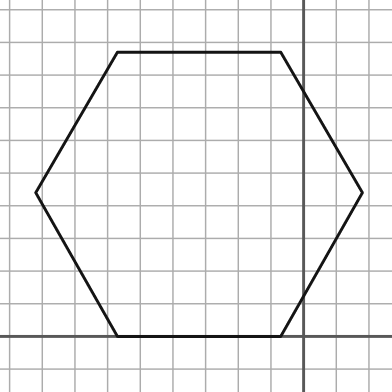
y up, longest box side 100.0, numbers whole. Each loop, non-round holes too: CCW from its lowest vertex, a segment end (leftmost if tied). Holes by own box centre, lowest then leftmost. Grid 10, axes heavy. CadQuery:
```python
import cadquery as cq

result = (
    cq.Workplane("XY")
    .moveTo(-57.0, 0.0)
    .lineTo(-7.0, 0.0)
    .lineTo(18.0, 44.0)
    .lineTo(-7.0, 87.0)
    .lineTo(-57.0, 87.0)
    .lineTo(-82.0, 44.0)
    .close()
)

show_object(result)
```